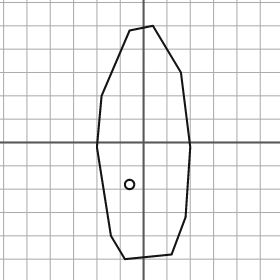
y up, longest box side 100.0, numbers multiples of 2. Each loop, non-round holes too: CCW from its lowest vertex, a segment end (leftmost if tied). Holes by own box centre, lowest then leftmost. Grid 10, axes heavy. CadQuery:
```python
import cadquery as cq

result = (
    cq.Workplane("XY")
    .moveTo(-8.0, -50.0)
    .lineTo(12.0, -48.0)
    .lineTo(18.0, -32.0)
    .lineTo(20.0, -2.0)
    .lineTo(16.0, 30.0)
    .lineTo(4.0, 50.0)
    .lineTo(-6.0, 48.0)
    .lineTo(-18.0, 20.0)
    .lineTo(-20.0, -2.0)
    .lineTo(-14.0, -40.0)
    .close()
    .moveTo(-6.0, -18.0)
    .circle(2.0)
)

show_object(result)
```